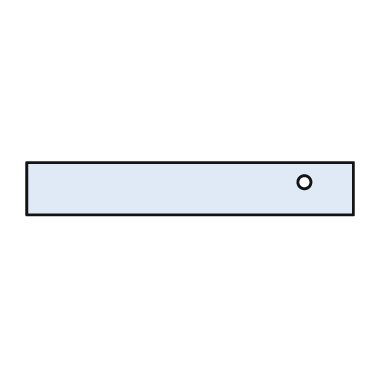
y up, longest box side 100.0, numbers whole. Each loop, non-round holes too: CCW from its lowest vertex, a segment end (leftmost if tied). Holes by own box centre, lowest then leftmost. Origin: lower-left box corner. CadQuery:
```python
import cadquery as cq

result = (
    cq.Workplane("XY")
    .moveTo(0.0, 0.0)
    .lineTo(100.0, 0.0)
    .lineTo(100.0, 16.0)
    .lineTo(0.0, 16.0)
    .close()
    .moveTo(85.0, 10.0)
    .circle(2.0)
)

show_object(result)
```